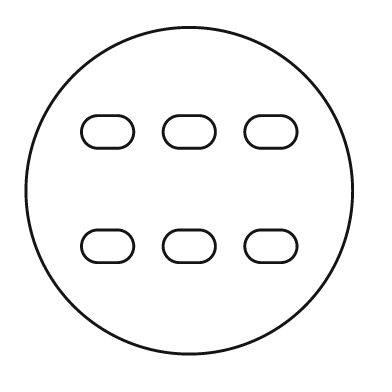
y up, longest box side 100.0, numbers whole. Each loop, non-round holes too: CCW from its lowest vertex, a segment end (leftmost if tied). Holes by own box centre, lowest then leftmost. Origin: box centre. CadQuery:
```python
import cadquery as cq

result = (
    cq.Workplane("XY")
    .moveTo(0.0, 0.0)
    .circle(50.0)
    .moveTo(-28.0, -22.0)
    .lineTo(-22.0, -22.0)
    .threePointArc((-17.0, -17.0), (-22.0, -12.0))
    .lineTo(-28.0, -12.0)
    .threePointArc((-33.0, -17.0), (-28.0, -22.0))
    .close()
    .moveTo(-3.0, -22.0)
    .lineTo(3.0, -22.0)
    .threePointArc((8.0, -17.0), (3.0, -12.0))
    .lineTo(-3.0, -12.0)
    .threePointArc((-8.0, -17.0), (-3.0, -22.0))
    .close()
    .moveTo(22.0, -22.0)
    .lineTo(28.0, -22.0)
    .threePointArc((33.0, -17.0), (28.0, -12.0))
    .lineTo(22.0, -12.0)
    .threePointArc((17.0, -17.0), (22.0, -22.0))
    .close()
    .moveTo(-28.0, 13.0)
    .lineTo(-22.0, 13.0)
    .threePointArc((-17.0, 18.0), (-22.0, 23.0))
    .lineTo(-28.0, 23.0)
    .threePointArc((-33.0, 18.0), (-28.0, 13.0))
    .close()
    .moveTo(-3.0, 13.0)
    .lineTo(3.0, 13.0)
    .threePointArc((8.0, 18.0), (3.0, 23.0))
    .lineTo(-3.0, 23.0)
    .threePointArc((-8.0, 18.0), (-3.0, 13.0))
    .close()
    .moveTo(22.0, 13.0)
    .lineTo(28.0, 13.0)
    .threePointArc((33.0, 18.0), (28.0, 23.0))
    .lineTo(22.0, 23.0)
    .threePointArc((17.0, 18.0), (22.0, 13.0))
    .close()
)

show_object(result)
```